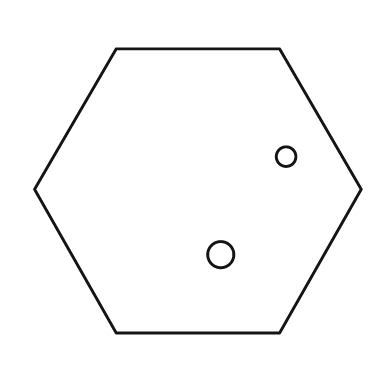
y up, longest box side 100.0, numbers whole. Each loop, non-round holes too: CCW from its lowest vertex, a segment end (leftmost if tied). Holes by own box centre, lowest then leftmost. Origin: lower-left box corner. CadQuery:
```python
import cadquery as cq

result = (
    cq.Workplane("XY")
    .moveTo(25.0, 0.0)
    .lineTo(75.0, 0.0)
    .lineTo(100.0, 44.0)
    .lineTo(75.0, 87.0)
    .lineTo(25.0, 87.0)
    .lineTo(0.0, 44.0)
    .close()
    .moveTo(57.0, 24.0)
    .circle(4.0)
    .moveTo(77.0, 54.0)
    .circle(3.0)
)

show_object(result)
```